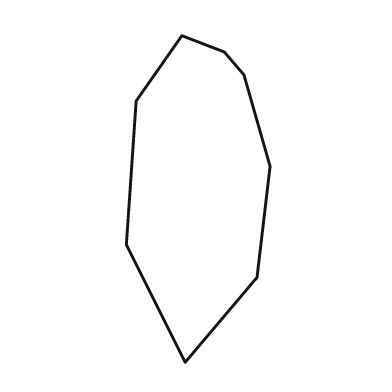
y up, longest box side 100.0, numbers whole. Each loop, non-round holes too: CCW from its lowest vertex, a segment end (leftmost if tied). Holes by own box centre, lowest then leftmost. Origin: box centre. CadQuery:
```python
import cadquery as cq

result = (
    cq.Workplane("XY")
    .moveTo(-4.0, -50.0)
    .lineTo(18.0, -24.0)
    .lineTo(22.0, 10.0)
    .lineTo(14.0, 38.0)
    .lineTo(8.0, 45.0)
    .lineTo(-5.0, 50.0)
    .lineTo(-19.0, 30.0)
    .lineTo(-22.0, -14.0)
    .close()
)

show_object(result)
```